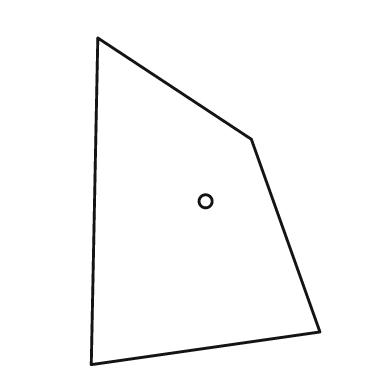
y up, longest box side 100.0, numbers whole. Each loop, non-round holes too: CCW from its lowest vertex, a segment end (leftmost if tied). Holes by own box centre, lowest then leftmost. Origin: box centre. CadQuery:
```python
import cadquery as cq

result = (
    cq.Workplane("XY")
    .moveTo(-35.0, -50.0)
    .lineTo(35.0, -40.0)
    .lineTo(14.0, 19.0)
    .lineTo(-33.0, 50.0)
    .close()
    .moveTo(0.0, 0.0)
    .circle(2.0)
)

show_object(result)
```